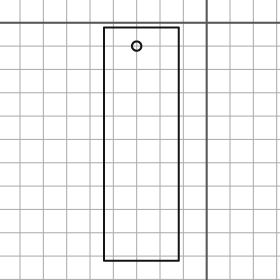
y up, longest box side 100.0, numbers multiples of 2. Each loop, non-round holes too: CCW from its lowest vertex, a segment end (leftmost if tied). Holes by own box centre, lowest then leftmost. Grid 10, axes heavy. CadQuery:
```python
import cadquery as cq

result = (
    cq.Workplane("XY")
    .moveTo(-44.0, -102.0)
    .lineTo(-12.0, -102.0)
    .lineTo(-12.0, -2.0)
    .lineTo(-44.0, -2.0)
    .close()
    .moveTo(-30.0, -10.0)
    .circle(2.0)
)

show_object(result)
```